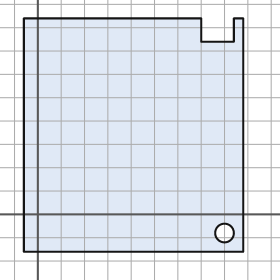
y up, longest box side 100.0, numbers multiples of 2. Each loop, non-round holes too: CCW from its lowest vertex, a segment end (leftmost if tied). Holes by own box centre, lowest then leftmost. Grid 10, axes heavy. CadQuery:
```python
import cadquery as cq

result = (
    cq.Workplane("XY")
    .moveTo(-6.0, -16.0)
    .lineTo(88.0, -16.0)
    .lineTo(88.0, 84.0)
    .lineTo(84.0, 84.0)
    .lineTo(84.0, 74.0)
    .lineTo(70.0, 74.0)
    .lineTo(70.0, 84.0)
    .lineTo(-6.0, 84.0)
    .close()
    .moveTo(80.0, -8.0)
    .circle(4.0)
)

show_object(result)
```